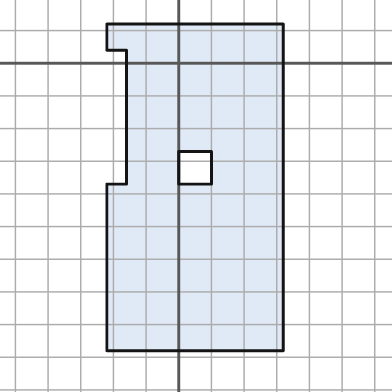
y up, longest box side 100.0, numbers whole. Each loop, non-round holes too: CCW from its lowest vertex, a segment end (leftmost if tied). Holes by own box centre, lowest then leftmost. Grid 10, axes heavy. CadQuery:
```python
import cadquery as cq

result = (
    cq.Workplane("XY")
    .moveTo(-22.0, -88.0)
    .lineTo(32.0, -88.0)
    .lineTo(32.0, 12.0)
    .lineTo(-22.0, 12.0)
    .lineTo(-22.0, 4.0)
    .lineTo(-16.0, 4.0)
    .lineTo(-16.0, -37.0)
    .lineTo(-22.0, -37.0)
    .close()
    .moveTo(0.0, -37.0)
    .lineTo(10.0, -37.0)
    .lineTo(10.0, -27.0)
    .lineTo(0.0, -27.0)
    .close()
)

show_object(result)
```